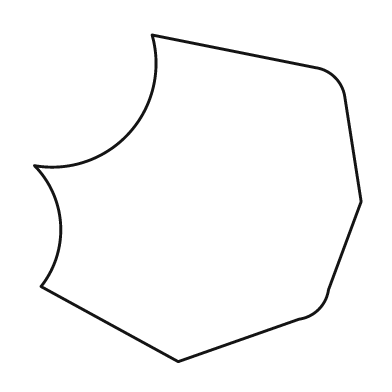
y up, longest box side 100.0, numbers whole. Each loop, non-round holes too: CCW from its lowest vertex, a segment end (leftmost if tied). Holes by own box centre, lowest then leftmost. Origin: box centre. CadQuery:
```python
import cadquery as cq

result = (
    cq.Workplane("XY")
    .moveTo(-6.0, -50.0)
    .lineTo(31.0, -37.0)
    .threePointArc((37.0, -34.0), (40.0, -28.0))
    .lineTo(50.0, -1.0)
    .lineTo(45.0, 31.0)
    .threePointArc((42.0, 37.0), (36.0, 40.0))
    .lineTo(-14.0, 50.0)
    .threePointArc((-21.0, 20.0), (-50.0, 10.0))
    .threePointArc((-42.0, -8.0), (-48.0, -27.0))
    .close()
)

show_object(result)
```